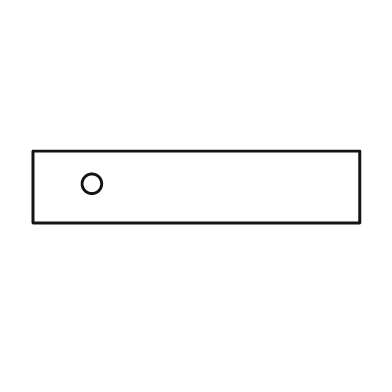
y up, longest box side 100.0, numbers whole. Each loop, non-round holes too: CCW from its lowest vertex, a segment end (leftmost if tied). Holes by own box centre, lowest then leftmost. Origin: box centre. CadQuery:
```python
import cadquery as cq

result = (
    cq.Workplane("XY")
    .moveTo(-50.0, -11.0)
    .lineTo(50.0, -11.0)
    .lineTo(50.0, 11.0)
    .lineTo(-50.0, 11.0)
    .close()
    .moveTo(-32.0, 1.0)
    .circle(3.0)
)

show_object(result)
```